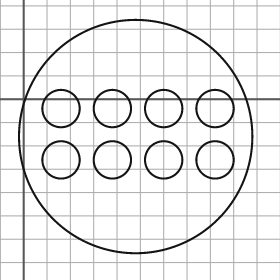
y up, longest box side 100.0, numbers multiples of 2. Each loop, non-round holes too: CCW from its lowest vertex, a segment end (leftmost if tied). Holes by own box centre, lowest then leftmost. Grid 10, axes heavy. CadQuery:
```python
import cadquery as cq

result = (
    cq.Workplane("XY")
    .moveTo(48.0, -16.0)
    .circle(50.0)
    .moveTo(16.0, -26.0)
    .circle(8.0)
    .moveTo(38.0, -26.0)
    .circle(8.0)
    .moveTo(60.0, -26.0)
    .circle(8.0)
    .moveTo(82.0, -26.0)
    .circle(8.0)
    .moveTo(16.0, -4.0)
    .circle(8.0)
    .moveTo(38.0, -4.0)
    .circle(8.0)
    .moveTo(60.0, -4.0)
    .circle(8.0)
    .moveTo(82.0, -4.0)
    .circle(8.0)
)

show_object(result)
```